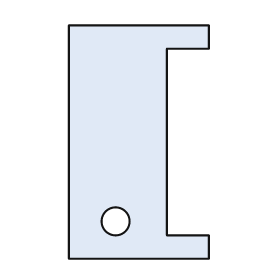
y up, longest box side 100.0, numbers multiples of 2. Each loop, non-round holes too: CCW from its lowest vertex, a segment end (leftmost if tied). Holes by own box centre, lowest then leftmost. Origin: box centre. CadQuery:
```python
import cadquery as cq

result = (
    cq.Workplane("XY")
    .moveTo(-30.0, -50.0)
    .lineTo(30.0, -50.0)
    .lineTo(30.0, -40.0)
    .lineTo(12.0, -40.0)
    .lineTo(12.0, 40.0)
    .lineTo(30.0, 40.0)
    .lineTo(30.0, 50.0)
    .lineTo(-30.0, 50.0)
    .close()
    .moveTo(-10.0, -34.0)
    .circle(6.0)
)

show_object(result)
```